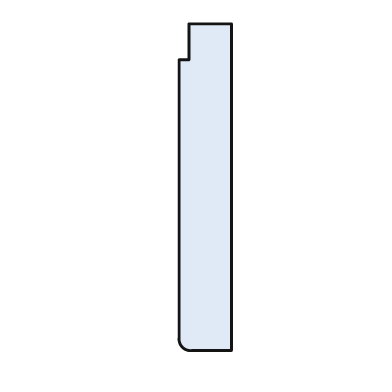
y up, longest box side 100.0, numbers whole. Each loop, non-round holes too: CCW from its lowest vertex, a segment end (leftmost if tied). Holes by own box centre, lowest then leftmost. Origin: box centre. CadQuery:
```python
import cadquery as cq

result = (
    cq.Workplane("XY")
    .moveTo(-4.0, -50.0)
    .lineTo(8.0, -50.0)
    .lineTo(8.0, 50.0)
    .lineTo(-5.0, 50.0)
    .lineTo(-5.0, 39.0)
    .lineTo(-8.0, 39.0)
    .lineTo(-8.0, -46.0)
    .threePointArc((-7.0, -49.0), (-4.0, -50.0))
    .close()
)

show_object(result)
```